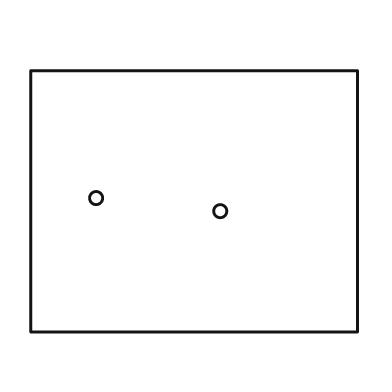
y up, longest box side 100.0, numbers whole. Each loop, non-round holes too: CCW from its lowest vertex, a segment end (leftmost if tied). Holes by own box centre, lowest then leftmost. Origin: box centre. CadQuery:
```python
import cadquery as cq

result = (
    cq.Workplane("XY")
    .moveTo(-50.0, -40.0)
    .lineTo(50.0, -40.0)
    .lineTo(50.0, 40.0)
    .lineTo(-50.0, 40.0)
    .close()
    .moveTo(8.0, -3.0)
    .circle(2.0)
    .moveTo(-30.0, 1.0)
    .circle(2.0)
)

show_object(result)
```